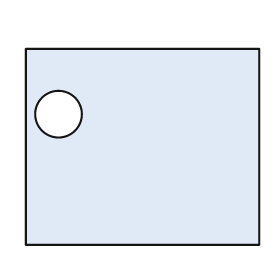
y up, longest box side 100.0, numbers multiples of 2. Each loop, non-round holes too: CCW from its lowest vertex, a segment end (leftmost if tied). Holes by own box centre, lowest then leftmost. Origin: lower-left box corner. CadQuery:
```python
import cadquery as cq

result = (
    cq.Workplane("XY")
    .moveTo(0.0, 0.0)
    .lineTo(100.0, 0.0)
    .lineTo(100.0, 84.0)
    .lineTo(0.0, 84.0)
    .close()
    .moveTo(14.0, 56.0)
    .circle(10.0)
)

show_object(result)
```